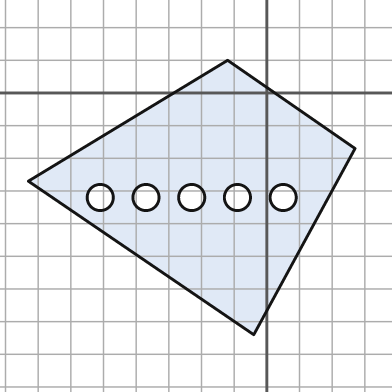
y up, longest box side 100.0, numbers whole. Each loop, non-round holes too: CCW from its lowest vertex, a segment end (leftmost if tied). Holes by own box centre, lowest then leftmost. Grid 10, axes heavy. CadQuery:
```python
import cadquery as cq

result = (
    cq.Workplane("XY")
    .moveTo(-4.0, -74.0)
    .lineTo(27.0, -17.0)
    .lineTo(-12.0, 10.0)
    .lineTo(-73.0, -27.0)
    .close()
    .moveTo(-51.0, -32.0)
    .circle(4.0)
    .moveTo(-37.0, -32.0)
    .circle(4.0)
    .moveTo(-23.0, -32.0)
    .circle(4.0)
    .moveTo(-9.0, -32.0)
    .circle(4.0)
    .moveTo(5.0, -32.0)
    .circle(4.0)
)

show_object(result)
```